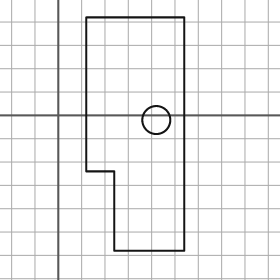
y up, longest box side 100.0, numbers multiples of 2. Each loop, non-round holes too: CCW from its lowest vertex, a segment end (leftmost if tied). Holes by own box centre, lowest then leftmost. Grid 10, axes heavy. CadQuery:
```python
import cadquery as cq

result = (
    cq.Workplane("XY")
    .moveTo(24.0, -58.0)
    .lineTo(54.0, -58.0)
    .lineTo(54.0, 42.0)
    .lineTo(12.0, 42.0)
    .lineTo(12.0, -24.0)
    .lineTo(24.0, -24.0)
    .close()
    .moveTo(42.0, -2.0)
    .circle(6.0)
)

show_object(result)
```